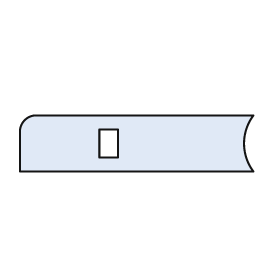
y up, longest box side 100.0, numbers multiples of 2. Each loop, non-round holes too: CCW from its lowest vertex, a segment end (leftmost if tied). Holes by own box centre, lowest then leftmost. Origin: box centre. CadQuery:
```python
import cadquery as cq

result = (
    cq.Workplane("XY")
    .moveTo(-50.0, -12.0)
    .lineTo(50.0, -12.0)
    .threePointArc((46.0, 0.0), (50.0, 12.0))
    .lineTo(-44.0, 12.0)
    .threePointArc((-48.0, 10.0), (-50.0, 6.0))
    .close()
    .moveTo(-16.0, -6.0)
    .lineTo(-8.0, -6.0)
    .lineTo(-8.0, 6.0)
    .lineTo(-16.0, 6.0)
    .close()
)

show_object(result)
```